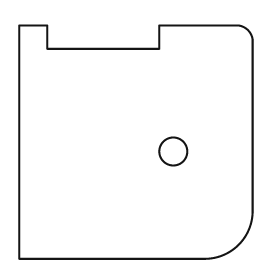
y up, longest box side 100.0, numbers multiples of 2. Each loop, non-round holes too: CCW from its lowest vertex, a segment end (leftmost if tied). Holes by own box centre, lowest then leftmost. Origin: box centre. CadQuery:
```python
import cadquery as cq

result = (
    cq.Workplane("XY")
    .moveTo(-50.0, -50.0)
    .lineTo(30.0, -50.0)
    .threePointArc((44.0, -44.0), (50.0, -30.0))
    .lineTo(50.0, 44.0)
    .threePointArc((48.0, 48.0), (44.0, 50.0))
    .lineTo(10.0, 50.0)
    .lineTo(10.0, 40.0)
    .lineTo(-38.0, 40.0)
    .lineTo(-38.0, 50.0)
    .lineTo(-50.0, 50.0)
    .close()
    .moveTo(16.0, -4.0)
    .circle(6.0)
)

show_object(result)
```